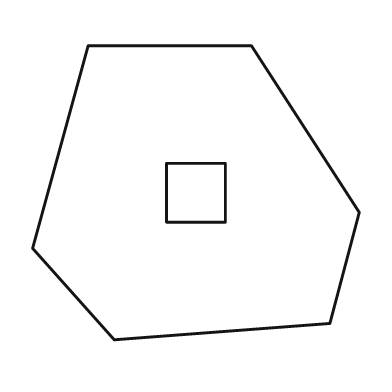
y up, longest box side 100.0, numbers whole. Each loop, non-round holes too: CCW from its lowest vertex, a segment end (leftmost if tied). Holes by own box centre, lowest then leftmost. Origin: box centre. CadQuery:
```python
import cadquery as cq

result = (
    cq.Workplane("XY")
    .moveTo(-25.0, -45.0)
    .lineTo(41.0, -40.0)
    .lineTo(50.0, -6.0)
    .lineTo(17.0, 45.0)
    .lineTo(-33.0, 45.0)
    .lineTo(-50.0, -17.0)
    .close()
    .moveTo(-9.0, -9.0)
    .lineTo(9.0, -9.0)
    .lineTo(9.0, 9.0)
    .lineTo(-9.0, 9.0)
    .close()
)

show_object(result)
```